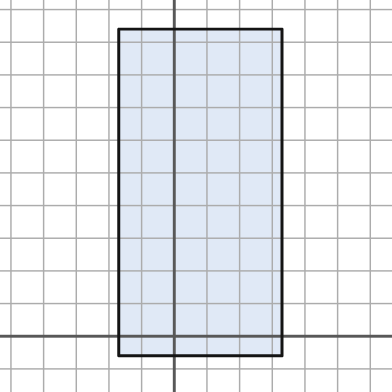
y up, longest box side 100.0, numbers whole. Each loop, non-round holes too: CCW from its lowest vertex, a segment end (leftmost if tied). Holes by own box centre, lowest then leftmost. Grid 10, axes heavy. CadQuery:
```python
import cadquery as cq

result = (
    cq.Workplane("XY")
    .moveTo(-17.0, -6.0)
    .lineTo(33.0, -6.0)
    .lineTo(33.0, 94.0)
    .lineTo(-17.0, 94.0)
    .close()
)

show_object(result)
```